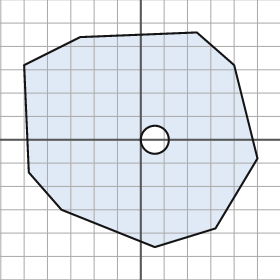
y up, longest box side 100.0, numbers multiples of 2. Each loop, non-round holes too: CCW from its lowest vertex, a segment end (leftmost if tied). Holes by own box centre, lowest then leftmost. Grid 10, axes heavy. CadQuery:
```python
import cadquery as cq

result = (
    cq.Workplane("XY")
    .moveTo(6.0, -46.0)
    .lineTo(32.0, -38.0)
    .lineTo(50.0, -8.0)
    .lineTo(40.0, 32.0)
    .lineTo(24.0, 46.0)
    .lineTo(-26.0, 44.0)
    .lineTo(-50.0, 32.0)
    .lineTo(-48.0, -14.0)
    .lineTo(-34.0, -30.0)
    .close()
    .moveTo(6.0, 0.0)
    .circle(6.0)
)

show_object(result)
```